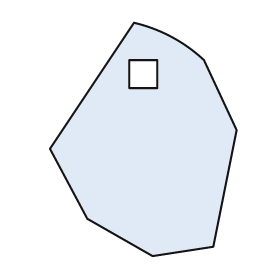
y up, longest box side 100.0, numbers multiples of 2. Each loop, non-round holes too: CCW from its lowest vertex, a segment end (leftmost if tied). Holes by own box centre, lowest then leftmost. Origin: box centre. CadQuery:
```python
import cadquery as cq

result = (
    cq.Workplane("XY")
    .moveTo(4.0, -50.0)
    .lineTo(30.0, -46.0)
    .lineTo(40.0, 4.0)
    .lineTo(26.0, 34.0)
    .threePointArc((12.0, 44.0), (-4.0, 50.0))
    .lineTo(-40.0, -4.0)
    .lineTo(-24.0, -34.0)
    .close()
    .moveTo(-6.0, 22.0)
    .lineTo(6.0, 22.0)
    .lineTo(6.0, 34.0)
    .lineTo(-6.0, 34.0)
    .close()
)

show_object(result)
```